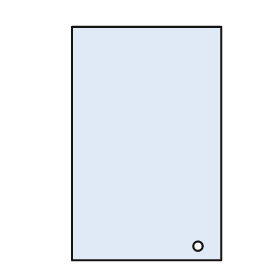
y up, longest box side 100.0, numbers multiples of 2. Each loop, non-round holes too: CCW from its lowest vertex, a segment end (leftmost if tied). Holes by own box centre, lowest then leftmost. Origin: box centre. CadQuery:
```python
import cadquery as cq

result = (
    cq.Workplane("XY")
    .moveTo(-32.0, -50.0)
    .lineTo(32.0, -50.0)
    .lineTo(32.0, 50.0)
    .lineTo(-32.0, 50.0)
    .close()
    .moveTo(22.0, -44.0)
    .circle(2.0)
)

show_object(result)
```